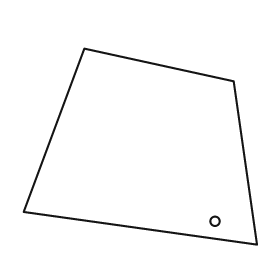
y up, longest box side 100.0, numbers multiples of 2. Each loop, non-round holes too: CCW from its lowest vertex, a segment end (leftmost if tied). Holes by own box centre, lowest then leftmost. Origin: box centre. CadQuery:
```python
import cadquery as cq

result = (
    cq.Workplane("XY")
    .moveTo(50.0, -42.0)
    .lineTo(40.0, 28.0)
    .lineTo(-24.0, 42.0)
    .lineTo(-50.0, -28.0)
    .close()
    .moveTo(32.0, -32.0)
    .circle(2.0)
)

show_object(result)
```